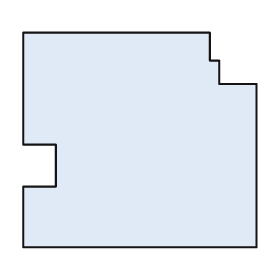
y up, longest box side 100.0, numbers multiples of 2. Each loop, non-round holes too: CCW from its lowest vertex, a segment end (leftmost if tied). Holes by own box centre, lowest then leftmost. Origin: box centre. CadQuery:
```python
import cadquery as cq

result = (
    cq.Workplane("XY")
    .moveTo(-50.0, -46.0)
    .lineTo(50.0, -46.0)
    .lineTo(50.0, 24.0)
    .lineTo(34.0, 24.0)
    .lineTo(34.0, 34.0)
    .lineTo(30.0, 34.0)
    .lineTo(30.0, 46.0)
    .lineTo(-50.0, 46.0)
    .lineTo(-50.0, -2.0)
    .lineTo(-36.0, -2.0)
    .lineTo(-36.0, -20.0)
    .lineTo(-50.0, -20.0)
    .close()
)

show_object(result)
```